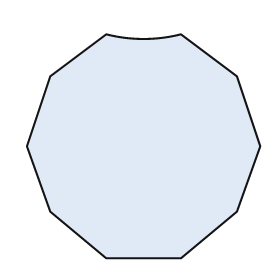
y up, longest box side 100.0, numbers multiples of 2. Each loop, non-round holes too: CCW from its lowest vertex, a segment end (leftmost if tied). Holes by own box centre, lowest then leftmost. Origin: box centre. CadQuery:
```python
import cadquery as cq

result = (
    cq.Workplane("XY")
    .moveTo(-16.0, -48.0)
    .lineTo(16.0, -48.0)
    .lineTo(40.0, -28.0)
    .lineTo(50.0, 0.0)
    .lineTo(40.0, 30.0)
    .lineTo(16.0, 48.0)
    .threePointArc((0.0, 46.0), (-16.0, 48.0))
    .lineTo(-40.0, 30.0)
    .lineTo(-50.0, 0.0)
    .lineTo(-40.0, -28.0)
    .close()
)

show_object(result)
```